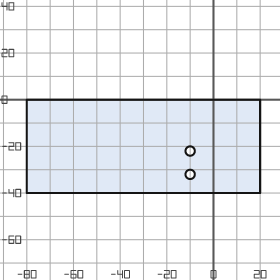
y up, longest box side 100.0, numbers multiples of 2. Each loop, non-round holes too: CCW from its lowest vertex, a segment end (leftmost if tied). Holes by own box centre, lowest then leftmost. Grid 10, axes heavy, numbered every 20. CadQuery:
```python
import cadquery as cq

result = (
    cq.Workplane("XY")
    .moveTo(-80.0, -40.0)
    .lineTo(20.0, -40.0)
    .lineTo(20.0, 0.0)
    .lineTo(-80.0, 0.0)
    .close()
    .moveTo(-10.0, -32.0)
    .circle(2.0)
    .moveTo(-10.0, -22.0)
    .circle(2.0)
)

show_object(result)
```